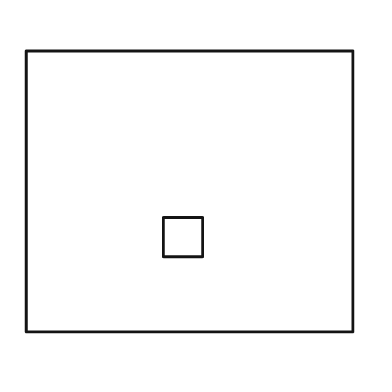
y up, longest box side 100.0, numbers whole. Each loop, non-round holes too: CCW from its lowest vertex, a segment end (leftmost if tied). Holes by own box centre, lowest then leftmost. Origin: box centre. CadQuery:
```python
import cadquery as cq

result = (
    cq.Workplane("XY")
    .moveTo(-50.0, -43.0)
    .lineTo(50.0, -43.0)
    .lineTo(50.0, 43.0)
    .lineTo(-50.0, 43.0)
    .close()
    .moveTo(-8.0, -20.0)
    .lineTo(4.0, -20.0)
    .lineTo(4.0, -8.0)
    .lineTo(-8.0, -8.0)
    .close()
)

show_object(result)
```